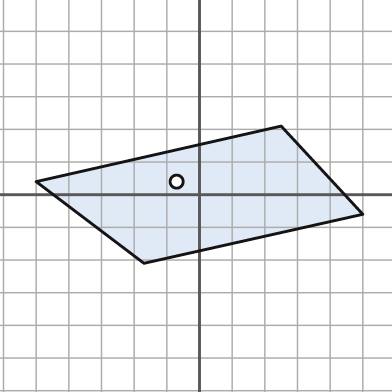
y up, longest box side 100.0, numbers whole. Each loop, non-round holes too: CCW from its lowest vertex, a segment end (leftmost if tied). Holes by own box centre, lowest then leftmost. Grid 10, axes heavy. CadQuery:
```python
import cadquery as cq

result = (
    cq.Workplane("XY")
    .moveTo(-17.0, -21.0)
    .lineTo(50.0, -6.0)
    .lineTo(25.0, 21.0)
    .lineTo(-50.0, 4.0)
    .close()
    .moveTo(-7.0, 4.0)
    .circle(2.0)
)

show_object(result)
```